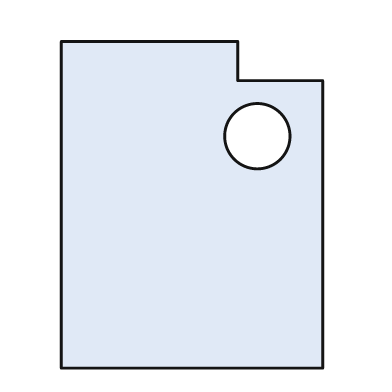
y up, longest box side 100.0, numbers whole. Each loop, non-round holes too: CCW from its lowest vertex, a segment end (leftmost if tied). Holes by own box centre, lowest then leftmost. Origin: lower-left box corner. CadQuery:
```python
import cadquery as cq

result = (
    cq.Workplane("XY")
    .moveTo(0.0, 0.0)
    .lineTo(80.0, 0.0)
    .lineTo(80.0, 88.0)
    .lineTo(54.0, 88.0)
    .lineTo(54.0, 100.0)
    .lineTo(0.0, 100.0)
    .close()
    .moveTo(60.0, 71.0)
    .circle(10.0)
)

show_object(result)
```